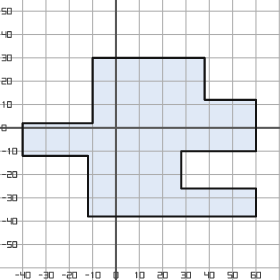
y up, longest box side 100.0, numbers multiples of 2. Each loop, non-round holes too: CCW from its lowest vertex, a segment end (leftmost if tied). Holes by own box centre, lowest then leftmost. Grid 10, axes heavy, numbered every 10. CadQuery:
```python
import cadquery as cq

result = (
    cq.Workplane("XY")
    .moveTo(-12.0, -38.0)
    .lineTo(60.0, -38.0)
    .lineTo(60.0, -26.0)
    .lineTo(28.0, -26.0)
    .lineTo(28.0, -10.0)
    .lineTo(60.0, -10.0)
    .lineTo(60.0, 12.0)
    .lineTo(38.0, 12.0)
    .lineTo(38.0, 30.0)
    .lineTo(-10.0, 30.0)
    .lineTo(-10.0, 2.0)
    .lineTo(-40.0, 2.0)
    .lineTo(-40.0, -12.0)
    .lineTo(-12.0, -12.0)
    .close()
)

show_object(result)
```